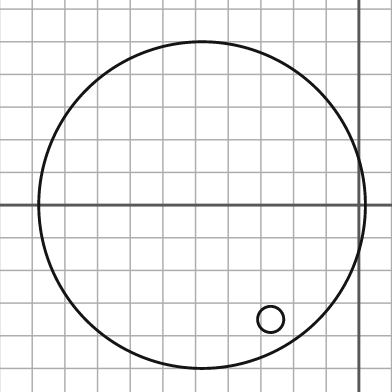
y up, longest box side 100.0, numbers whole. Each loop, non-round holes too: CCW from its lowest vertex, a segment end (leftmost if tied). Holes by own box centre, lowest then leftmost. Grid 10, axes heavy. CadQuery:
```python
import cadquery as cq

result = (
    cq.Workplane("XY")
    .moveTo(-48.0, 0.0)
    .circle(50.0)
    .moveTo(-27.0, -35.0)
    .circle(4.0)
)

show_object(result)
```